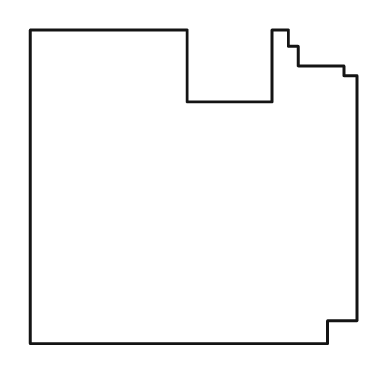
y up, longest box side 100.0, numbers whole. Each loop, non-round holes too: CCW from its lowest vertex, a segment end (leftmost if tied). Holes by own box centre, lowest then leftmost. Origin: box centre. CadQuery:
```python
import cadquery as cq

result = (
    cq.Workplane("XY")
    .moveTo(-50.0, -48.0)
    .lineTo(41.0, -48.0)
    .lineTo(41.0, -41.0)
    .lineTo(50.0, -41.0)
    .lineTo(50.0, 34.0)
    .lineTo(46.0, 34.0)
    .lineTo(46.0, 37.0)
    .lineTo(32.0, 37.0)
    .lineTo(32.0, 43.0)
    .lineTo(29.0, 43.0)
    .lineTo(29.0, 48.0)
    .lineTo(24.0, 48.0)
    .lineTo(24.0, 26.0)
    .lineTo(-2.0, 26.0)
    .lineTo(-2.0, 48.0)
    .lineTo(-50.0, 48.0)
    .close()
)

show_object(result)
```